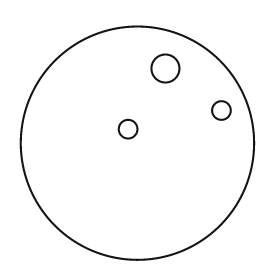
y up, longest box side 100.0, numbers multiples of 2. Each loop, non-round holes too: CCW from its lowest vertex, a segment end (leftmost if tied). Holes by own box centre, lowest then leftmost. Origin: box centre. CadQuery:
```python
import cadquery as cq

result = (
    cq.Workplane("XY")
    .moveTo(0.0, 0.0)
    .circle(50.0)
    .moveTo(-4.0, 6.0)
    .circle(4.0)
    .moveTo(36.0, 14.0)
    .circle(4.0)
    .moveTo(12.0, 32.0)
    .circle(6.0)
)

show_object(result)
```